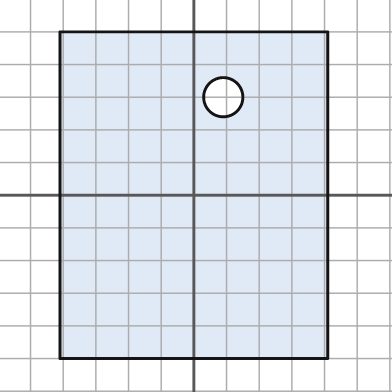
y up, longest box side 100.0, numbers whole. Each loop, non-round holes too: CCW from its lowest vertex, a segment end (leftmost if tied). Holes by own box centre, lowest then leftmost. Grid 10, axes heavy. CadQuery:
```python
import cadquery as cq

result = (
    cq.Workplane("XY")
    .moveTo(-41.0, -50.0)
    .lineTo(41.0, -50.0)
    .lineTo(41.0, 50.0)
    .lineTo(-41.0, 50.0)
    .close()
    .moveTo(9.0, 30.0)
    .circle(6.0)
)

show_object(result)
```